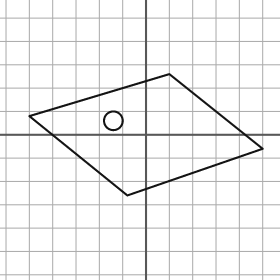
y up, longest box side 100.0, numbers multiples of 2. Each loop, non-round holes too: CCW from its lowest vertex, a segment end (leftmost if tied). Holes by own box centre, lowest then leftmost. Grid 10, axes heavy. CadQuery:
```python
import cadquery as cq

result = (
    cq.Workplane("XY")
    .moveTo(-8.0, -26.0)
    .lineTo(50.0, -6.0)
    .lineTo(10.0, 26.0)
    .lineTo(-50.0, 8.0)
    .close()
    .moveTo(-14.0, 6.0)
    .circle(4.0)
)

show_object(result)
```